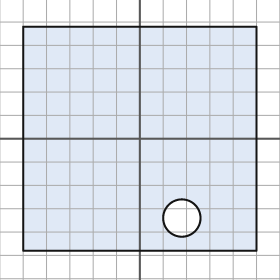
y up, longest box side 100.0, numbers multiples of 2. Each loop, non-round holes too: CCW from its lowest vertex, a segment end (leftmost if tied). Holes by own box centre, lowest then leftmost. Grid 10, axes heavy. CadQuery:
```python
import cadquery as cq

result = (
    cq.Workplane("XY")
    .moveTo(-50.0, -48.0)
    .lineTo(50.0, -48.0)
    .lineTo(50.0, 48.0)
    .lineTo(-50.0, 48.0)
    .close()
    .moveTo(18.0, -34.0)
    .circle(8.0)
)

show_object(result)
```